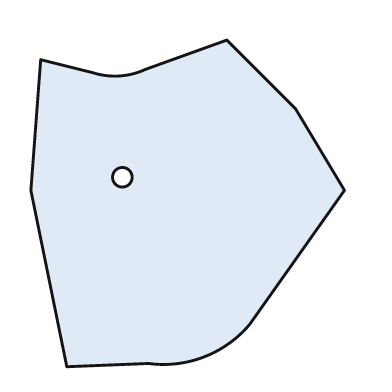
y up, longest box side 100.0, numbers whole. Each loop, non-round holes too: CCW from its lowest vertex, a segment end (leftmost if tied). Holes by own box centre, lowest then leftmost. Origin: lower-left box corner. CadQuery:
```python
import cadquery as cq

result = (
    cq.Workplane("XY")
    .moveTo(11.0, 0.0)
    .lineTo(36.0, 1.0)
    .threePointArc((53.0, 3.0), (67.0, 13.0))
    .lineTo(96.0, 54.0)
    .lineTo(81.0, 79.0)
    .lineTo(60.0, 100.0)
    .lineTo(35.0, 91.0)
    .threePointArc((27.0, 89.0), (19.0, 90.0))
    .lineTo(3.0, 94.0)
    .lineTo(0.0, 54.0)
    .close()
    .moveTo(28.0, 58.0)
    .circle(3.0)
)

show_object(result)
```